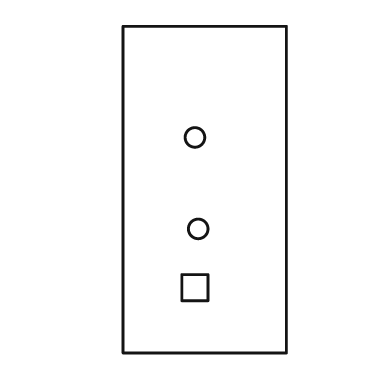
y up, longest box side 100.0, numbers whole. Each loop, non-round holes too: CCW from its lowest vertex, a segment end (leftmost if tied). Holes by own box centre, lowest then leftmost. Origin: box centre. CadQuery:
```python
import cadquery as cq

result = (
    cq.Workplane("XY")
    .moveTo(-25.0, -50.0)
    .lineTo(25.0, -50.0)
    .lineTo(25.0, 50.0)
    .lineTo(-25.0, 50.0)
    .close()
    .moveTo(-7.0, -34.0)
    .lineTo(1.0, -34.0)
    .lineTo(1.0, -26.0)
    .lineTo(-7.0, -26.0)
    .close()
    .moveTo(-2.0, -12.0)
    .circle(3.0)
    .moveTo(-3.0, 16.0)
    .circle(3.0)
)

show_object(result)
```